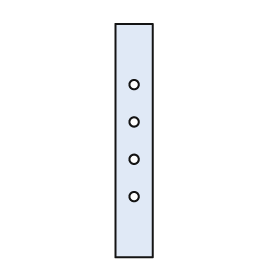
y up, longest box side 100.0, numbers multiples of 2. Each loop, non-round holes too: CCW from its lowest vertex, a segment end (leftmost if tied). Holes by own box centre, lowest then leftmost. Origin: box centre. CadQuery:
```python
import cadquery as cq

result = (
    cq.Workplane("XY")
    .moveTo(-8.0, -50.0)
    .lineTo(8.0, -50.0)
    .lineTo(8.0, 50.0)
    .lineTo(-8.0, 50.0)
    .close()
    .moveTo(0.0, -24.0)
    .circle(2.0)
    .moveTo(0.0, -8.0)
    .circle(2.0)
    .moveTo(0.0, 8.0)
    .circle(2.0)
    .moveTo(0.0, 24.0)
    .circle(2.0)
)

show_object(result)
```